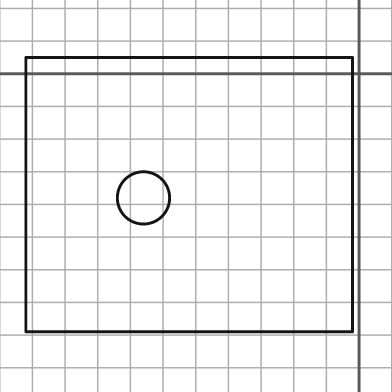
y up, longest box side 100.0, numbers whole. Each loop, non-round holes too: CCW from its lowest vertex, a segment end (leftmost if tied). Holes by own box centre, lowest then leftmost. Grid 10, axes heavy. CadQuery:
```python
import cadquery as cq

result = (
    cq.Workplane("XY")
    .moveTo(-102.0, -79.0)
    .lineTo(-2.0, -79.0)
    .lineTo(-2.0, 5.0)
    .lineTo(-102.0, 5.0)
    .close()
    .moveTo(-66.0, -38.0)
    .circle(8.0)
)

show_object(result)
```